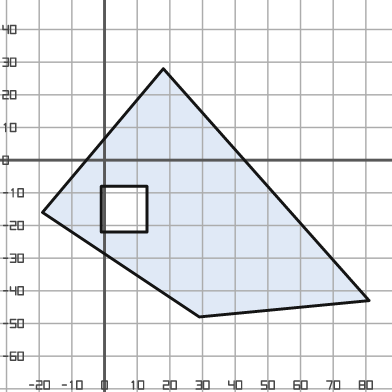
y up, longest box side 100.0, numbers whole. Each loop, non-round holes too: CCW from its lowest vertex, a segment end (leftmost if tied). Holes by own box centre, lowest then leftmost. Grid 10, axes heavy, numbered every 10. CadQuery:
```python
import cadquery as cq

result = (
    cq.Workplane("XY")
    .moveTo(29.0, -48.0)
    .lineTo(81.0, -43.0)
    .lineTo(18.0, 28.0)
    .lineTo(-19.0, -16.0)
    .close()
    .moveTo(-1.0, -22.0)
    .lineTo(13.0, -22.0)
    .lineTo(13.0, -8.0)
    .lineTo(-1.0, -8.0)
    .close()
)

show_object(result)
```